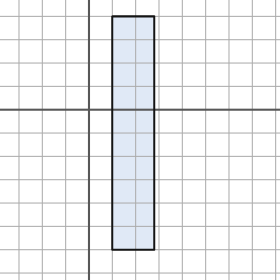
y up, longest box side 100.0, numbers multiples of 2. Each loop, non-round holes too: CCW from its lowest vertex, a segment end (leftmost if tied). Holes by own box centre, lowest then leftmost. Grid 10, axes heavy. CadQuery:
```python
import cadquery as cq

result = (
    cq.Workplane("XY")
    .moveTo(10.0, -60.0)
    .lineTo(28.0, -60.0)
    .lineTo(28.0, 40.0)
    .lineTo(10.0, 40.0)
    .close()
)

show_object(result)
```